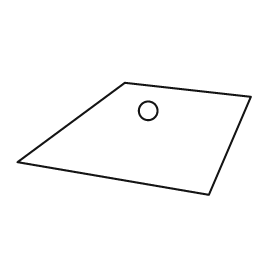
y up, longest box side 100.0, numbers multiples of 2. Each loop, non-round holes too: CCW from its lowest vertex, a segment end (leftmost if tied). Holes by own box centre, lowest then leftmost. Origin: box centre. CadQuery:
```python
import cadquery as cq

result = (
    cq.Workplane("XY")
    .moveTo(32.0, -24.0)
    .lineTo(50.0, 18.0)
    .lineTo(-4.0, 24.0)
    .lineTo(-50.0, -10.0)
    .close()
    .moveTo(6.0, 12.0)
    .circle(4.0)
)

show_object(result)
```